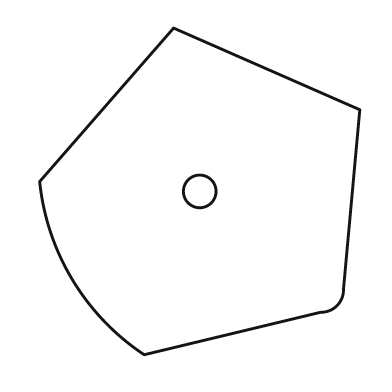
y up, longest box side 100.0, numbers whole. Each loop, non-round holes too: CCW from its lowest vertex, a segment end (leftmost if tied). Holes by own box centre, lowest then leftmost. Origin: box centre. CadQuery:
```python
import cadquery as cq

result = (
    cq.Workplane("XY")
    .moveTo(-17.0, -50.0)
    .lineTo(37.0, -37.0)
    .threePointArc((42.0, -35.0), (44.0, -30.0))
    .lineTo(49.0, 25.0)
    .lineTo(-8.0, 50.0)
    .lineTo(-49.0, 3.0)
    .threePointArc((-39.0, -27.0), (-17.0, -50.0))
    .close()
    .moveTo(0.0, 0.0)
    .circle(5.0)
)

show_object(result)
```